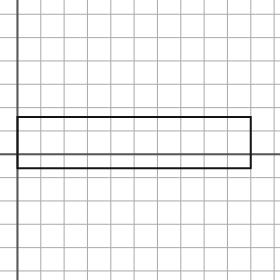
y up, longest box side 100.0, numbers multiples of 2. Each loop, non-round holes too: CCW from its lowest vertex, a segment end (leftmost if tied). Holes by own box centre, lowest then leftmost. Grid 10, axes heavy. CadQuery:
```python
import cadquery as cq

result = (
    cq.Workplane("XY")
    .moveTo(0.0, -6.0)
    .lineTo(100.0, -6.0)
    .lineTo(100.0, 16.0)
    .lineTo(0.0, 16.0)
    .close()
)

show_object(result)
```